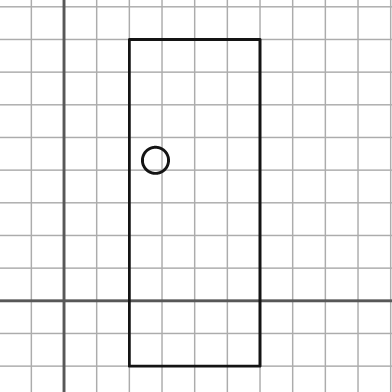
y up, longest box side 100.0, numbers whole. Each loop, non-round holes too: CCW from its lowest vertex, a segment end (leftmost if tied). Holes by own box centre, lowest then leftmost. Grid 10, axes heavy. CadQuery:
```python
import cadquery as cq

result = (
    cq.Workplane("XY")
    .moveTo(20.0, -20.0)
    .lineTo(60.0, -20.0)
    .lineTo(60.0, 80.0)
    .lineTo(20.0, 80.0)
    .close()
    .moveTo(28.0, 43.0)
    .circle(4.0)
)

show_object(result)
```